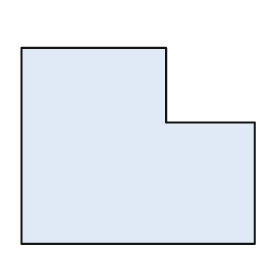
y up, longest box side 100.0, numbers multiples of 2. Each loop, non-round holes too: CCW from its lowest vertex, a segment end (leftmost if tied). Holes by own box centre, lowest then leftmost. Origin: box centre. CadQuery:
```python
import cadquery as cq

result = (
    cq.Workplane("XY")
    .moveTo(-50.0, -42.0)
    .lineTo(50.0, -42.0)
    .lineTo(50.0, 10.0)
    .lineTo(12.0, 10.0)
    .lineTo(12.0, 42.0)
    .lineTo(-50.0, 42.0)
    .close()
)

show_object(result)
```